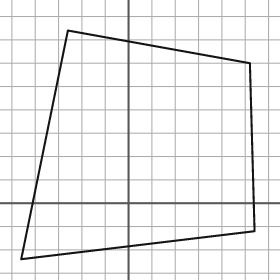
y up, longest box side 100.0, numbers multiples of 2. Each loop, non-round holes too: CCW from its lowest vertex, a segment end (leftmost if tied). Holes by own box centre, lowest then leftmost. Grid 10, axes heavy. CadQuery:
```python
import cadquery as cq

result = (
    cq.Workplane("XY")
    .moveTo(-46.0, -24.0)
    .lineTo(54.0, -12.0)
    .lineTo(52.0, 60.0)
    .lineTo(-26.0, 74.0)
    .close()
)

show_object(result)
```